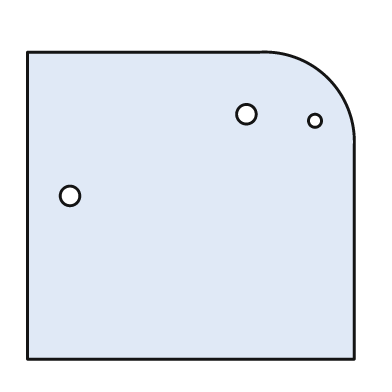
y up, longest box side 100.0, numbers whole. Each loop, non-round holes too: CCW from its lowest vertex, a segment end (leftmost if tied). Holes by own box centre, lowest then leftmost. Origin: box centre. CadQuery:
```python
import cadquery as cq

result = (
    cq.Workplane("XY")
    .moveTo(-50.0, -47.0)
    .lineTo(50.0, -47.0)
    .lineTo(50.0, 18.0)
    .threePointArc((42.0, 39.0), (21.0, 47.0))
    .lineTo(-50.0, 47.0)
    .close()
    .moveTo(-37.0, 3.0)
    .circle(3.0)
    .moveTo(38.0, 26.0)
    .circle(2.0)
    .moveTo(17.0, 28.0)
    .circle(3.0)
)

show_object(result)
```